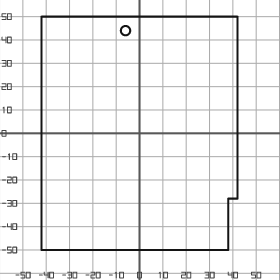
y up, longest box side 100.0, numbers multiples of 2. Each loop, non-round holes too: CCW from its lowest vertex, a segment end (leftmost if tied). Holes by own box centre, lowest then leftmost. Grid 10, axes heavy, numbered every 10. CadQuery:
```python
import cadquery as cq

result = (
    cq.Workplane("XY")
    .moveTo(-42.0, -50.0)
    .lineTo(38.0, -50.0)
    .lineTo(38.0, -28.0)
    .lineTo(42.0, -28.0)
    .lineTo(42.0, 50.0)
    .lineTo(-42.0, 50.0)
    .close()
    .moveTo(-6.0, 44.0)
    .circle(2.0)
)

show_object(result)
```